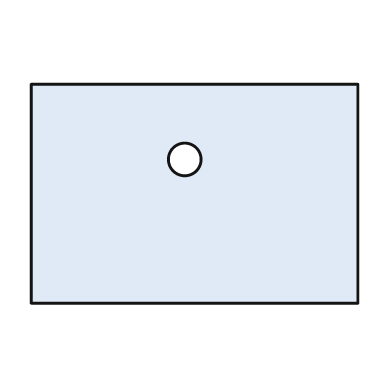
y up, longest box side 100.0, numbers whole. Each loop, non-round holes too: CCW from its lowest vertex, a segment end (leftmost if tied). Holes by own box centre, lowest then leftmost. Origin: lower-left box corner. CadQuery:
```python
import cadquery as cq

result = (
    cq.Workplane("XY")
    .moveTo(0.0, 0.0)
    .lineTo(100.0, 0.0)
    .lineTo(100.0, 67.0)
    .lineTo(0.0, 67.0)
    .close()
    .moveTo(47.0, 44.0)
    .circle(5.0)
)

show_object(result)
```